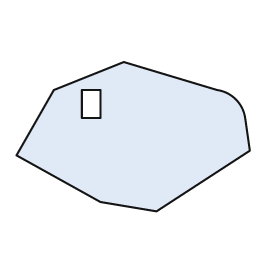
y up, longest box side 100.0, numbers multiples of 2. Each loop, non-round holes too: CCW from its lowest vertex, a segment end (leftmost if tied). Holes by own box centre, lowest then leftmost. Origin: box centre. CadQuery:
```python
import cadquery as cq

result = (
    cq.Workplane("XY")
    .moveTo(10.0, -32.0)
    .lineTo(50.0, -6.0)
    .lineTo(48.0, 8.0)
    .threePointArc((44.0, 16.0), (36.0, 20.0))
    .lineTo(-4.0, 32.0)
    .lineTo(-34.0, 20.0)
    .lineTo(-50.0, -8.0)
    .lineTo(-14.0, -28.0)
    .close()
    .moveTo(-22.0, 8.0)
    .lineTo(-14.0, 8.0)
    .lineTo(-14.0, 20.0)
    .lineTo(-22.0, 20.0)
    .close()
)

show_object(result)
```